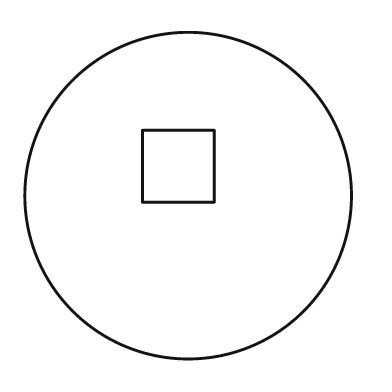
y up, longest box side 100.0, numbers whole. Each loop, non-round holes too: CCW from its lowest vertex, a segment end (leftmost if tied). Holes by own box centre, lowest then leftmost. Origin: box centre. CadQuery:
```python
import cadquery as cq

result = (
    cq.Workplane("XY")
    .moveTo(0.0, 0.0)
    .circle(50.0)
    .moveTo(-14.0, -2.0)
    .lineTo(8.0, -2.0)
    .lineTo(8.0, 20.0)
    .lineTo(-14.0, 20.0)
    .close()
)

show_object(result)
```